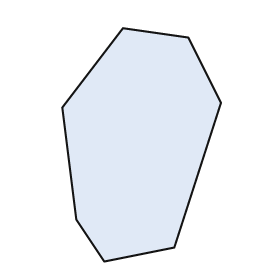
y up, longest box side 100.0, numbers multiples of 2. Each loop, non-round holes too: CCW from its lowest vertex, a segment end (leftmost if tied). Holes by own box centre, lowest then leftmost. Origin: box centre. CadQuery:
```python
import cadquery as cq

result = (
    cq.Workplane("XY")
    .moveTo(-16.0, -50.0)
    .lineTo(14.0, -44.0)
    .lineTo(34.0, 18.0)
    .lineTo(20.0, 46.0)
    .lineTo(-8.0, 50.0)
    .lineTo(-34.0, 16.0)
    .lineTo(-28.0, -32.0)
    .close()
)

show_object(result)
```